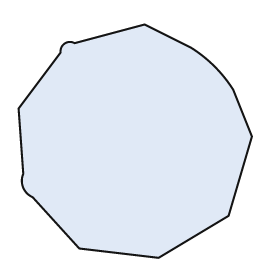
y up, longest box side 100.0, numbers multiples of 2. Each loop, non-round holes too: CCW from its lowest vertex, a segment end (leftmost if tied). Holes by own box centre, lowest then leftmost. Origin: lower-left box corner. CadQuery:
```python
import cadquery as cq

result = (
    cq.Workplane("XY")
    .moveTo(60.0, 0.0)
    .lineTo(90.0, 18.0)
    .lineTo(100.0, 52.0)
    .lineTo(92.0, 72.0)
    .threePointArc((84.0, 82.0), (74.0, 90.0))
    .lineTo(54.0, 100.0)
    .lineTo(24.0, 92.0)
    .threePointArc((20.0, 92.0), (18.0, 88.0))
    .lineTo(0.0, 64.0)
    .lineTo(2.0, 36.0)
    .threePointArc((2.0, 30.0), (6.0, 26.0))
    .lineTo(26.0, 4.0)
    .close()
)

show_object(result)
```